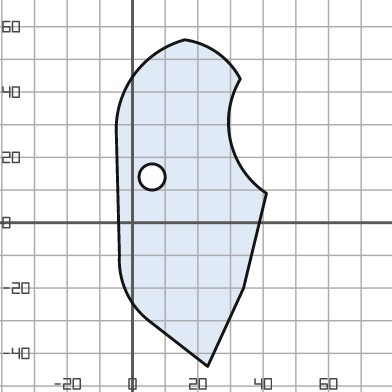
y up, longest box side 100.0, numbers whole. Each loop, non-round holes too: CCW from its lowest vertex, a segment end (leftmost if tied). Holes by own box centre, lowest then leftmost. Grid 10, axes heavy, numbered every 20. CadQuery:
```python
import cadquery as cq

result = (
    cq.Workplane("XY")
    .moveTo(23.0, -44.0)
    .lineTo(34.0, -20.0)
    .lineTo(41.0, 9.0)
    .threePointArc((30.0, 25.0), (33.0, 44.0))
    .threePointArc((26.0, 52.0), (16.0, 56.0))
    .threePointArc((1.0, 46.0), (-5.0, 29.0))
    .lineTo(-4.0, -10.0)
    .threePointArc((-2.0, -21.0), (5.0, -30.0))
    .close()
    .moveTo(6.0, 14.0)
    .circle(4.0)
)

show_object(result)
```